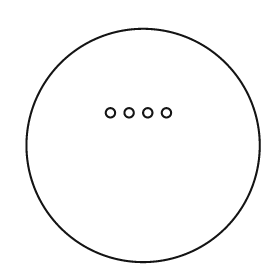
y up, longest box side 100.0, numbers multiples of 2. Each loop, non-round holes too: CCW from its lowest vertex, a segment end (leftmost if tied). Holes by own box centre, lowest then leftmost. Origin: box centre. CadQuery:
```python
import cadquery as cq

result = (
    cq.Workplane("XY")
    .moveTo(0.0, 0.0)
    .circle(50.0)
    .moveTo(-14.0, 14.0)
    .circle(2.0)
    .moveTo(-6.0, 14.0)
    .circle(2.0)
    .moveTo(2.0, 14.0)
    .circle(2.0)
    .moveTo(10.0, 14.0)
    .circle(2.0)
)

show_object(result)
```